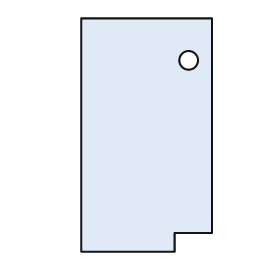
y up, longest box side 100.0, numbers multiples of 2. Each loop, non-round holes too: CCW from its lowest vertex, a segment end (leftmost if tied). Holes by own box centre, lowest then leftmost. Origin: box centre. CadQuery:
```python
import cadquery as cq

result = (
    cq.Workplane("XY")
    .moveTo(-28.0, -50.0)
    .lineTo(12.0, -50.0)
    .lineTo(12.0, -42.0)
    .lineTo(28.0, -42.0)
    .lineTo(28.0, 50.0)
    .lineTo(-28.0, 50.0)
    .close()
    .moveTo(18.0, 32.0)
    .circle(4.0)
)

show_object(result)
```